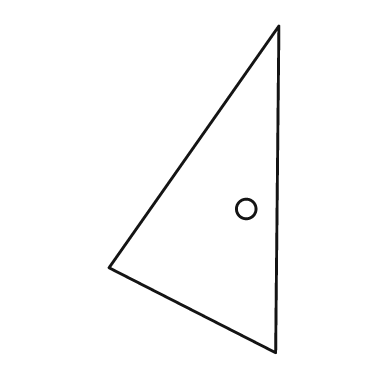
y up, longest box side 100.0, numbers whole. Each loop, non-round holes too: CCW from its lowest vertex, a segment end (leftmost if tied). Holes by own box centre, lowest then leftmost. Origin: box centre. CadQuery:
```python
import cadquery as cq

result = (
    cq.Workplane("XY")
    .moveTo(25.0, -50.0)
    .lineTo(26.0, 50.0)
    .lineTo(-26.0, -24.0)
    .close()
    .moveTo(16.0, -6.0)
    .circle(3.0)
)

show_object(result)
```